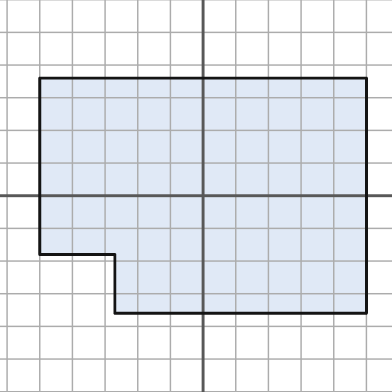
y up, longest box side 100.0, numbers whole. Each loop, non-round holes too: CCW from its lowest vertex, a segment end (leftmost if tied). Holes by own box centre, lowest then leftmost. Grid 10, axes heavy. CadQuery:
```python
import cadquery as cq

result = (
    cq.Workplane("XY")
    .moveTo(-27.0, -36.0)
    .lineTo(50.0, -36.0)
    .lineTo(50.0, 36.0)
    .lineTo(-50.0, 36.0)
    .lineTo(-50.0, -18.0)
    .lineTo(-27.0, -18.0)
    .close()
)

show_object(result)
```